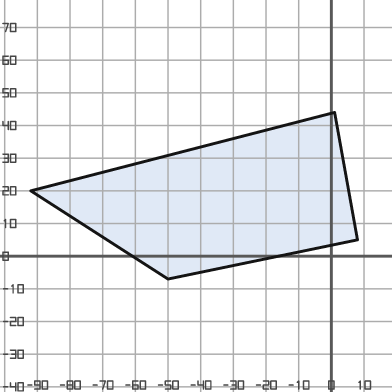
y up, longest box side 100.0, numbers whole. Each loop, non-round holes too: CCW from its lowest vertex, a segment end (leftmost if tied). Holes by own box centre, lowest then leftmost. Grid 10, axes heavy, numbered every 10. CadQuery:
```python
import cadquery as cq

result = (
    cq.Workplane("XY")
    .moveTo(-50.0, -7.0)
    .lineTo(8.0, 5.0)
    .lineTo(1.0, 44.0)
    .lineTo(-92.0, 20.0)
    .close()
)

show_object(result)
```